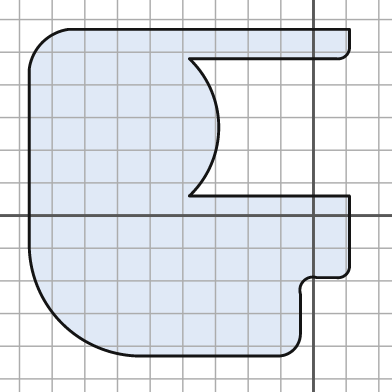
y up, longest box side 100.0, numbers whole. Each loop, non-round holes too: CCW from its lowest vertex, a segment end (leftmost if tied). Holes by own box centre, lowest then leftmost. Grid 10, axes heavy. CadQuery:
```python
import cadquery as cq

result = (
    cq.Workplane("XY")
    .moveTo(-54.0, -43.0)
    .lineTo(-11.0, -43.0)
    .threePointArc((-6.0, -41.0), (-4.0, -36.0))
    .lineTo(-4.0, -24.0)
    .threePointArc((-3.0, -20.0), (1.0, -19.0))
    .lineTo(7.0, -19.0)
    .threePointArc((10.0, -18.0), (11.0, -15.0))
    .lineTo(11.0, 6.0)
    .lineTo(-38.0, 6.0)
    .threePointArc((-29.0, 27.0), (-38.0, 48.0))
    .lineTo(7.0, 48.0)
    .threePointArc((10.0, 49.0), (11.0, 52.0))
    .lineTo(11.0, 57.0)
    .lineTo(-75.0, 57.0)
    .threePointArc((-83.0, 53.0), (-87.0, 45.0))
    .lineTo(-87.0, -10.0)
    .threePointArc((-77.0, -33.0), (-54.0, -43.0))
    .close()
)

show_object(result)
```